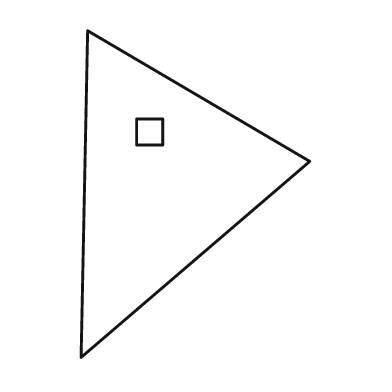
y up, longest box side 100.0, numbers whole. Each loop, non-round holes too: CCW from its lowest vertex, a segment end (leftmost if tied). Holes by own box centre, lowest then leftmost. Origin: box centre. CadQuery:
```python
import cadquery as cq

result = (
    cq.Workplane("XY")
    .moveTo(-35.0, -50.0)
    .lineTo(35.0, 10.0)
    .lineTo(-33.0, 50.0)
    .close()
    .moveTo(-18.0, 15.0)
    .lineTo(-10.0, 15.0)
    .lineTo(-10.0, 23.0)
    .lineTo(-18.0, 23.0)
    .close()
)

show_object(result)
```